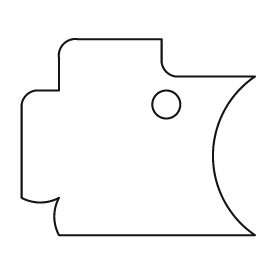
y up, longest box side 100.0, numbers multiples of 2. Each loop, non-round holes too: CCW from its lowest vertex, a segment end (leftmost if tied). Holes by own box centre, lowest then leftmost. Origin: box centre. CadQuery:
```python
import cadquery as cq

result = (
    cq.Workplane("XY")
    .moveTo(-34.0, -42.0)
    .lineTo(50.0, -42.0)
    .threePointArc((32.0, -8.0), (50.0, 26.0))
    .lineTo(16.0, 26.0)
    .threePointArc((12.0, 28.0), (10.0, 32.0))
    .lineTo(10.0, 42.0)
    .lineTo(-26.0, 42.0)
    .threePointArc((-32.0, 40.0), (-34.0, 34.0))
    .lineTo(-34.0, 20.0)
    .lineTo(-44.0, 20.0)
    .threePointArc((-48.0, 18.0), (-50.0, 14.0))
    .lineTo(-50.0, -26.0)
    .threePointArc((-42.0, -28.0), (-34.0, -26.0))
    .threePointArc((-36.0, -34.0), (-34.0, -42.0))
    .close()
    .moveTo(12.0, 14.0)
    .circle(6.0)
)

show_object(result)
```